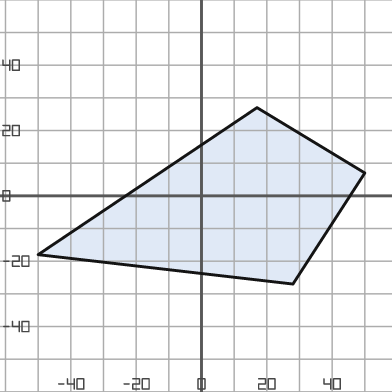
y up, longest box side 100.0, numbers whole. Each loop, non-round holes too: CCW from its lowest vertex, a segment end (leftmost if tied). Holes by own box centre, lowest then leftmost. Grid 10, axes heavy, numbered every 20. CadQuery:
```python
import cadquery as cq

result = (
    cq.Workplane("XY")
    .moveTo(28.0, -27.0)
    .lineTo(50.0, 7.0)
    .lineTo(17.0, 27.0)
    .lineTo(-50.0, -18.0)
    .close()
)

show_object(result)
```